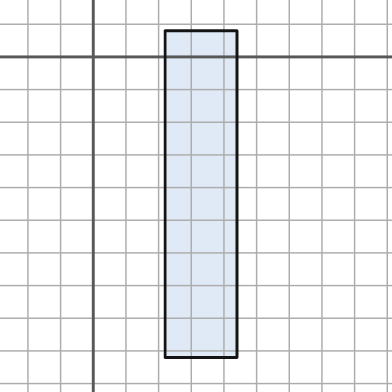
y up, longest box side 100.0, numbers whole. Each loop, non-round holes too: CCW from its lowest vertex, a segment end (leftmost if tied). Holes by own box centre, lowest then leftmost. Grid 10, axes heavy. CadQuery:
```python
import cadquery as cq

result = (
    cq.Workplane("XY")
    .moveTo(22.0, -92.0)
    .lineTo(44.0, -92.0)
    .lineTo(44.0, 8.0)
    .lineTo(22.0, 8.0)
    .close()
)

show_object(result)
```